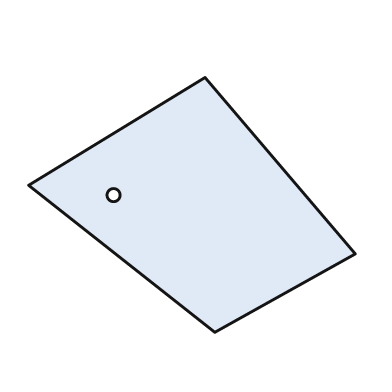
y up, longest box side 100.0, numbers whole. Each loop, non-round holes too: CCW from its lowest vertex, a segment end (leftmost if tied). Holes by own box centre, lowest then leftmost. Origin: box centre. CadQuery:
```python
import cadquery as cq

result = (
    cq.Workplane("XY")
    .moveTo(7.0, -39.0)
    .lineTo(50.0, -15.0)
    .lineTo(4.0, 39.0)
    .lineTo(-50.0, 6.0)
    .close()
    .moveTo(-24.0, 3.0)
    .circle(2.0)
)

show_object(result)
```